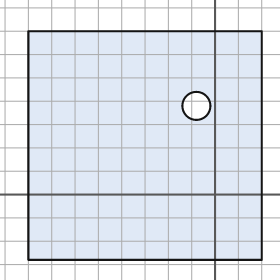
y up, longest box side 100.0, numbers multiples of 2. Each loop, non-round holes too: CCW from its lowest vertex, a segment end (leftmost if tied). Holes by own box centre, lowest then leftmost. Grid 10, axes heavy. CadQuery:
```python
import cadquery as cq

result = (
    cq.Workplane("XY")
    .moveTo(-80.0, -28.0)
    .lineTo(20.0, -28.0)
    .lineTo(20.0, 70.0)
    .lineTo(-80.0, 70.0)
    .close()
    .moveTo(-8.0, 38.0)
    .circle(6.0)
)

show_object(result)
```